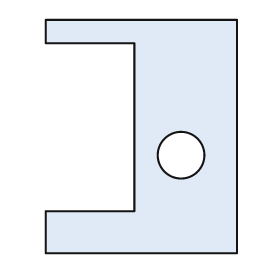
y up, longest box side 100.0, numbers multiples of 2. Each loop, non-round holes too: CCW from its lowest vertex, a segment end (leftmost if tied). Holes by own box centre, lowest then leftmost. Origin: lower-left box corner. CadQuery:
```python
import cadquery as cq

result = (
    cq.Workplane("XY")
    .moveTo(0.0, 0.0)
    .lineTo(82.0, 0.0)
    .lineTo(82.0, 100.0)
    .lineTo(0.0, 100.0)
    .lineTo(0.0, 90.0)
    .lineTo(38.0, 90.0)
    .lineTo(38.0, 18.0)
    .lineTo(0.0, 18.0)
    .close()
    .moveTo(58.0, 42.0)
    .circle(10.0)
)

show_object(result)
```